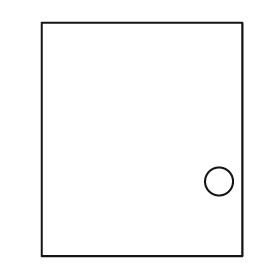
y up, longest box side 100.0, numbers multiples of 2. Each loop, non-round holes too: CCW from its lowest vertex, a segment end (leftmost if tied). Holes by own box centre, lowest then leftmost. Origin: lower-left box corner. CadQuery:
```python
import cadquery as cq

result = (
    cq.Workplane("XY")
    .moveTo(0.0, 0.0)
    .lineTo(86.0, 0.0)
    .lineTo(86.0, 100.0)
    .lineTo(0.0, 100.0)
    .close()
    .moveTo(76.0, 32.0)
    .circle(6.0)
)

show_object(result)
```